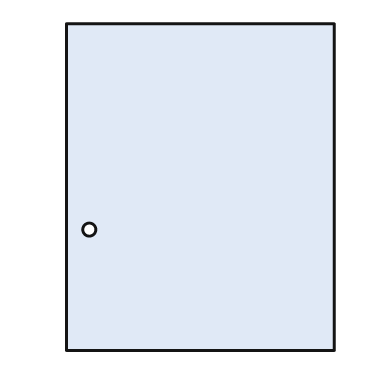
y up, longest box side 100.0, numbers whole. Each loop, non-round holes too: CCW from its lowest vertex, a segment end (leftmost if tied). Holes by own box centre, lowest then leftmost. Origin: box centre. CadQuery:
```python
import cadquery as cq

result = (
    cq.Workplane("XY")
    .moveTo(-41.0, -50.0)
    .lineTo(41.0, -50.0)
    .lineTo(41.0, 50.0)
    .lineTo(-41.0, 50.0)
    .close()
    .moveTo(-34.0, -13.0)
    .circle(2.0)
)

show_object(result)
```